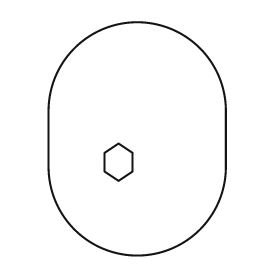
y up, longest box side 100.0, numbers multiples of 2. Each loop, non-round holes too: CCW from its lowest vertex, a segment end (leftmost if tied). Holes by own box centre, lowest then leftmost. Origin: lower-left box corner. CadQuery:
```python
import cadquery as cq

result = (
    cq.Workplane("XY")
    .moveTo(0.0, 38.0)
    .threePointArc((38.0, 0.0), (76.0, 38.0))
    .lineTo(76.0, 62.0)
    .threePointArc((38.0, 100.0), (0.0, 62.0))
    .close()
    .moveTo(30.0, 32.0)
    .lineTo(36.0, 36.0)
    .lineTo(36.0, 44.0)
    .lineTo(30.0, 48.0)
    .lineTo(24.0, 44.0)
    .lineTo(24.0, 36.0)
    .close()
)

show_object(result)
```